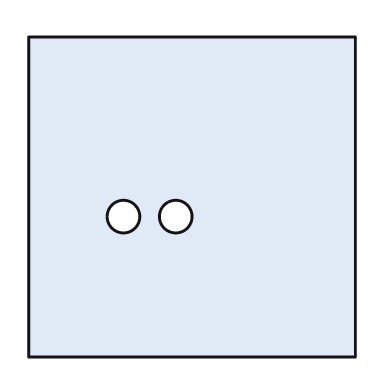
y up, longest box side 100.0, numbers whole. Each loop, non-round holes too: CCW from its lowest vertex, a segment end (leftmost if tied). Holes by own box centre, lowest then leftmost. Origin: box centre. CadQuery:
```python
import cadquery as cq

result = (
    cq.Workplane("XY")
    .moveTo(-50.0, -49.0)
    .lineTo(50.0, -49.0)
    .lineTo(50.0, 49.0)
    .lineTo(-50.0, 49.0)
    .close()
    .moveTo(-21.0, -6.0)
    .circle(5.0)
    .moveTo(-5.0, -6.0)
    .circle(5.0)
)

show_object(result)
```